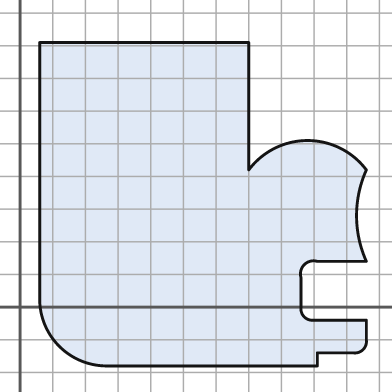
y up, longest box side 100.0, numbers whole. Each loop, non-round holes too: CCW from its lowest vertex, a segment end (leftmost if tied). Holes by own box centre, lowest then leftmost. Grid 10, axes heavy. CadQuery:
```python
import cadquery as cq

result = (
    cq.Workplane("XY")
    .moveTo(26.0, -18.0)
    .lineTo(91.0, -18.0)
    .lineTo(91.0, -14.0)
    .lineTo(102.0, -14.0)
    .threePointArc((105.0, -13.0), (106.0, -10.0))
    .lineTo(106.0, -4.0)
    .lineTo(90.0, -4.0)
    .threePointArc((87.0, -3.0), (86.0, 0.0))
    .lineTo(86.0, 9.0)
    .threePointArc((87.0, 13.0), (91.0, 14.0))
    .lineTo(106.0, 14.0)
    .threePointArc((103.0, 28.0), (106.0, 42.0))
    .threePointArc((88.0, 51.0), (70.0, 42.0))
    .lineTo(70.0, 81.0)
    .lineTo(6.0, 81.0)
    .lineTo(6.0, 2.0)
    .threePointArc((12.0, -12.0), (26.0, -18.0))
    .close()
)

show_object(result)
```